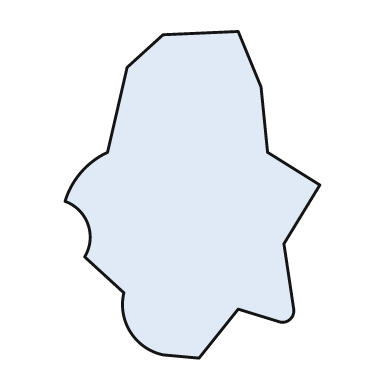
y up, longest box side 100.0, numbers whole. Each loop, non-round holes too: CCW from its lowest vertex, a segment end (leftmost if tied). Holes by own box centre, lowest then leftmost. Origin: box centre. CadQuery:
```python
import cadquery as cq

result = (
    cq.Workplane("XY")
    .moveTo(2.0, -50.0)
    .lineTo(14.0, -35.0)
    .lineTo(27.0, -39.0)
    .threePointArc((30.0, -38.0), (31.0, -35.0))
    .lineTo(28.0, -15.0)
    .lineTo(39.0, 3.0)
    .lineTo(23.0, 13.0)
    .lineTo(21.0, 33.0)
    .lineTo(14.0, 50.0)
    .lineTo(-9.0, 49.0)
    .lineTo(-20.0, 39.0)
    .lineTo(-26.0, 13.0)
    .threePointArc((-34.0, 7.0), (-39.0, -2.0))
    .threePointArc((-32.0, -9.0), (-33.0, -19.0))
    .lineTo(-21.0, -30.0)
    .threePointArc((-19.0, -42.0), (-9.0, -49.0))
    .close()
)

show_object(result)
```